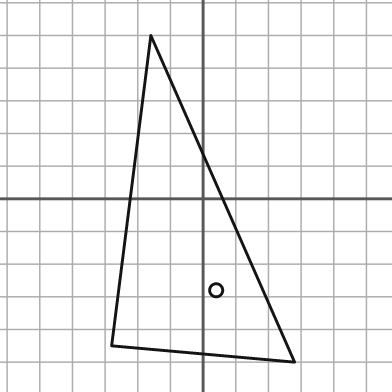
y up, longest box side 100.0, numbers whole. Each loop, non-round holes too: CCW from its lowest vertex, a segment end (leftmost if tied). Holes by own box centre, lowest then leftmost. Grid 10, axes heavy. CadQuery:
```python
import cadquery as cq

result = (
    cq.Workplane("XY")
    .moveTo(28.0, -50.0)
    .lineTo(-16.0, 50.0)
    .lineTo(-28.0, -45.0)
    .close()
    .moveTo(4.0, -28.0)
    .circle(2.0)
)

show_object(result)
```